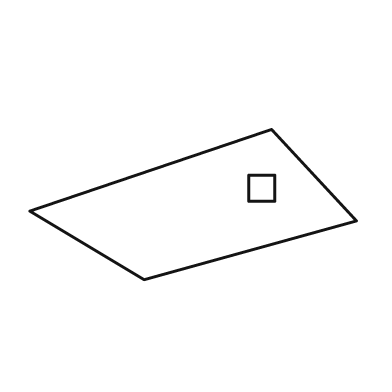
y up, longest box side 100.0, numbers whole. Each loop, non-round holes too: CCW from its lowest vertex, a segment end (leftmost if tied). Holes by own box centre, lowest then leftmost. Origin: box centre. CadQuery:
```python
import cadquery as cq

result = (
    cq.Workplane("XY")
    .moveTo(-15.0, -23.0)
    .lineTo(50.0, -5.0)
    .lineTo(24.0, 23.0)
    .lineTo(-50.0, -2.0)
    .close()
    .moveTo(17.0, 1.0)
    .lineTo(25.0, 1.0)
    .lineTo(25.0, 9.0)
    .lineTo(17.0, 9.0)
    .close()
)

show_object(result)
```